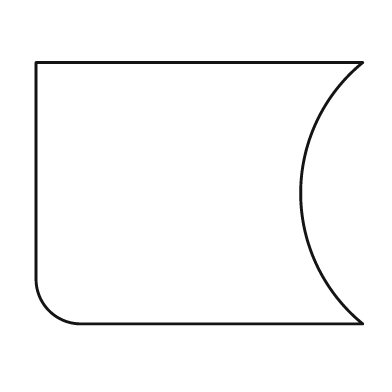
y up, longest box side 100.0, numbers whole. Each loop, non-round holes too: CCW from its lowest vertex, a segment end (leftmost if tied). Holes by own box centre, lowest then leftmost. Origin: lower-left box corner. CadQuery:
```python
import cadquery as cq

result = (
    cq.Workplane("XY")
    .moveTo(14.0, 0.0)
    .lineTo(100.0, 0.0)
    .threePointArc((81.0, 40.0), (100.0, 80.0))
    .lineTo(0.0, 80.0)
    .lineTo(0.0, 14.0)
    .threePointArc((4.0, 4.0), (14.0, 0.0))
    .close()
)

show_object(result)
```